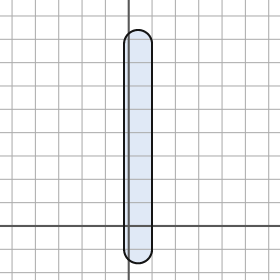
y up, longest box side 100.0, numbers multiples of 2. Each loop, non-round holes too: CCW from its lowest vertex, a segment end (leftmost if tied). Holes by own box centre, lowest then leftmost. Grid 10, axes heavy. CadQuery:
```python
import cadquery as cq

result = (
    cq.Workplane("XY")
    .moveTo(-2.0, -10.0)
    .threePointArc((4.0, -16.0), (10.0, -10.0))
    .lineTo(10.0, 78.0)
    .threePointArc((4.0, 84.0), (-2.0, 78.0))
    .close()
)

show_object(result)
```